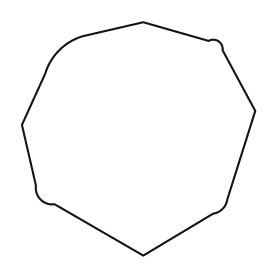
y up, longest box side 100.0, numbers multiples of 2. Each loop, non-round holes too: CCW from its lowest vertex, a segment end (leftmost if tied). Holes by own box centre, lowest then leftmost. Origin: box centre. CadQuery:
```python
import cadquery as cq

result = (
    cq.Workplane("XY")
    .moveTo(2.0, -50.0)
    .lineTo(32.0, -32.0)
    .threePointArc((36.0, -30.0), (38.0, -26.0))
    .lineTo(50.0, 12.0)
    .lineTo(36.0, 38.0)
    .threePointArc((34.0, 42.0), (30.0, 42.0))
    .lineTo(2.0, 50.0)
    .lineTo(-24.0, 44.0)
    .threePointArc((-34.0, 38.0), (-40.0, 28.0))
    .lineTo(-50.0, 6.0)
    .lineTo(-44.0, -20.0)
    .threePointArc((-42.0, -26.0), (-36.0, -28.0))
    .close()
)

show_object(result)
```